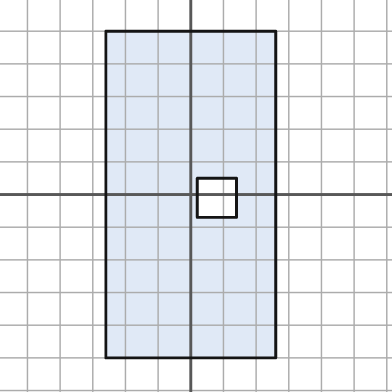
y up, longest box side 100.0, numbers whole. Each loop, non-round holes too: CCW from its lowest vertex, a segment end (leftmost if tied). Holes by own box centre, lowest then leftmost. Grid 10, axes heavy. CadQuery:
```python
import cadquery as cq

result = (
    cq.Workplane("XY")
    .moveTo(-26.0, -50.0)
    .lineTo(26.0, -50.0)
    .lineTo(26.0, 50.0)
    .lineTo(-26.0, 50.0)
    .close()
    .moveTo(2.0, -7.0)
    .lineTo(14.0, -7.0)
    .lineTo(14.0, 5.0)
    .lineTo(2.0, 5.0)
    .close()
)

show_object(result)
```